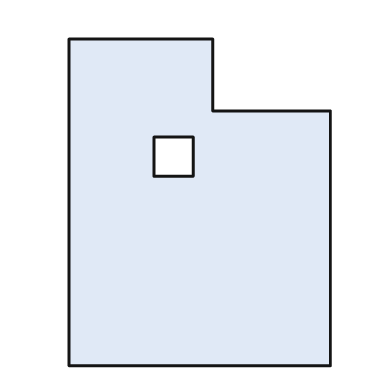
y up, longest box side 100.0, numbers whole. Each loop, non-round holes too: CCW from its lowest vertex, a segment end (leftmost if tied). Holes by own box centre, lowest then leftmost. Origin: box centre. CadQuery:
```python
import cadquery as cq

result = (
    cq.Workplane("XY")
    .moveTo(-40.0, -50.0)
    .lineTo(40.0, -50.0)
    .lineTo(40.0, 28.0)
    .lineTo(4.0, 28.0)
    .lineTo(4.0, 50.0)
    .lineTo(-40.0, 50.0)
    .close()
    .moveTo(-14.0, 8.0)
    .lineTo(-2.0, 8.0)
    .lineTo(-2.0, 20.0)
    .lineTo(-14.0, 20.0)
    .close()
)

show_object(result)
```